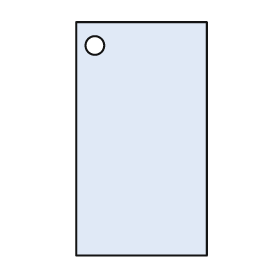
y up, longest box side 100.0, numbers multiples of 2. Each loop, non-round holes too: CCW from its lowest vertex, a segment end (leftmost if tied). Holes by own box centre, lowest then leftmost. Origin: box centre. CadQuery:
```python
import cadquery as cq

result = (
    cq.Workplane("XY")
    .moveTo(-28.0, -50.0)
    .lineTo(28.0, -50.0)
    .lineTo(28.0, 50.0)
    .lineTo(-28.0, 50.0)
    .close()
    .moveTo(-20.0, 40.0)
    .circle(4.0)
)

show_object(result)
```